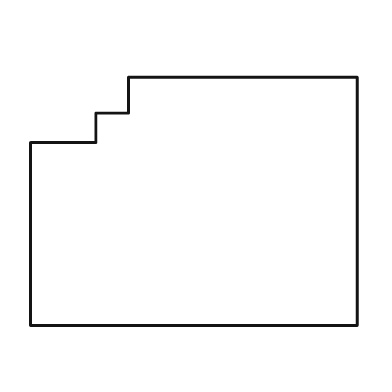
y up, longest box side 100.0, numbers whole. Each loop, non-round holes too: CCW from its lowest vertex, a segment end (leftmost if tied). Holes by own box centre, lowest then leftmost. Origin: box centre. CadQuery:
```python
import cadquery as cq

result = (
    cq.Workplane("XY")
    .moveTo(-50.0, -38.0)
    .lineTo(50.0, -38.0)
    .lineTo(50.0, 38.0)
    .lineTo(-20.0, 38.0)
    .lineTo(-20.0, 27.0)
    .lineTo(-30.0, 27.0)
    .lineTo(-30.0, 18.0)
    .lineTo(-50.0, 18.0)
    .close()
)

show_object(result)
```